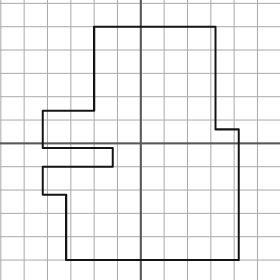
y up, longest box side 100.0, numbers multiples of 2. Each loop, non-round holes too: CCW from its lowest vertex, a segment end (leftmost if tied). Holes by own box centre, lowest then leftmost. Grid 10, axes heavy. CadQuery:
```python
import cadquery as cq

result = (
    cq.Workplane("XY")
    .moveTo(-32.0, -50.0)
    .lineTo(42.0, -50.0)
    .lineTo(42.0, 6.0)
    .lineTo(32.0, 6.0)
    .lineTo(32.0, 50.0)
    .lineTo(-20.0, 50.0)
    .lineTo(-20.0, 14.0)
    .lineTo(-42.0, 14.0)
    .lineTo(-42.0, -2.0)
    .lineTo(-12.0, -2.0)
    .lineTo(-12.0, -10.0)
    .lineTo(-42.0, -10.0)
    .lineTo(-42.0, -22.0)
    .lineTo(-32.0, -22.0)
    .close()
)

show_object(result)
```